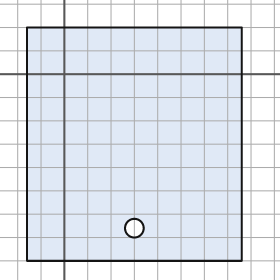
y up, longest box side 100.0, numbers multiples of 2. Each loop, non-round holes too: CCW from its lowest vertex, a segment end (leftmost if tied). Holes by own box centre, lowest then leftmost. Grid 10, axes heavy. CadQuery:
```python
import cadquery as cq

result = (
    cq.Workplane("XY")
    .moveTo(-16.0, -80.0)
    .lineTo(76.0, -80.0)
    .lineTo(76.0, 20.0)
    .lineTo(-16.0, 20.0)
    .close()
    .moveTo(30.0, -66.0)
    .circle(4.0)
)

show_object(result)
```